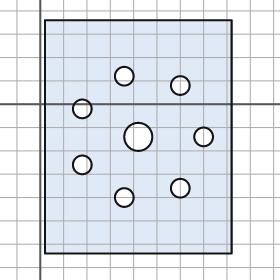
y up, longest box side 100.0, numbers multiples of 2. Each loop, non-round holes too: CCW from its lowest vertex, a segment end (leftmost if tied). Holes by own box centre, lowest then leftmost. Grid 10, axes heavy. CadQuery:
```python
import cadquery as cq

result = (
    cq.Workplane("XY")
    .moveTo(2.0, -64.0)
    .lineTo(82.0, -64.0)
    .lineTo(82.0, 36.0)
    .lineTo(2.0, 36.0)
    .close()
    .moveTo(36.0, -40.0)
    .circle(4.0)
    .moveTo(60.0, -36.0)
    .circle(4.0)
    .moveTo(18.0, -26.0)
    .circle(4.0)
    .moveTo(42.0, -14.0)
    .circle(6.0)
    .moveTo(70.0, -14.0)
    .circle(4.0)
    .moveTo(18.0, -2.0)
    .circle(4.0)
    .moveTo(60.0, 8.0)
    .circle(4.0)
    .moveTo(36.0, 12.0)
    .circle(4.0)
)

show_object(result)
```